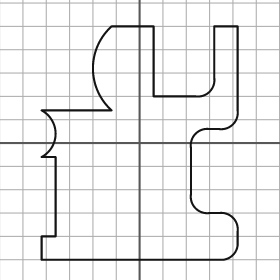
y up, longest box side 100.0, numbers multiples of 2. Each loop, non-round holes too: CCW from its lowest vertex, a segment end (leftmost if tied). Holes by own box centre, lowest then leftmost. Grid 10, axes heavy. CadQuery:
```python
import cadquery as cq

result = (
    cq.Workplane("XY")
    .moveTo(-42.0, -50.0)
    .lineTo(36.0, -50.0)
    .threePointArc((40.0, -48.0), (42.0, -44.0))
    .lineTo(42.0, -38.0)
    .threePointArc((40.0, -32.0), (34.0, -30.0))
    .lineTo(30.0, -30.0)
    .threePointArc((24.0, -28.0), (22.0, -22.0))
    .lineTo(22.0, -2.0)
    .threePointArc((24.0, 4.0), (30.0, 6.0))
    .lineTo(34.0, 6.0)
    .threePointArc((40.0, 8.0), (42.0, 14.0))
    .lineTo(42.0, 50.0)
    .lineTo(32.0, 50.0)
    .lineTo(32.0, 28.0)
    .threePointArc((30.0, 22.0), (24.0, 20.0))
    .lineTo(6.0, 20.0)
    .lineTo(6.0, 50.0)
    .lineTo(-12.0, 50.0)
    .threePointArc((-20.0, 32.0), (-12.0, 14.0))
    .lineTo(-42.0, 14.0)
    .threePointArc((-36.0, 4.0), (-42.0, -6.0))
    .lineTo(-36.0, -6.0)
    .lineTo(-36.0, -40.0)
    .lineTo(-42.0, -40.0)
    .close()
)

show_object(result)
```